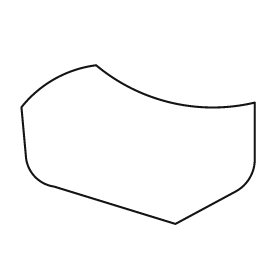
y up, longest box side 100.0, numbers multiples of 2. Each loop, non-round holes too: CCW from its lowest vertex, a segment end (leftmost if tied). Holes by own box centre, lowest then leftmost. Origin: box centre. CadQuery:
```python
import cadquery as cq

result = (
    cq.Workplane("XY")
    .moveTo(16.0, -34.0)
    .lineTo(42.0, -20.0)
    .threePointArc((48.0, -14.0), (50.0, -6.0))
    .lineTo(50.0, 18.0)
    .threePointArc((14.0, 18.0), (-18.0, 34.0))
    .threePointArc((-36.0, 28.0), (-50.0, 16.0))
    .lineTo(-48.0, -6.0)
    .threePointArc((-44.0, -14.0), (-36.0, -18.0))
    .close()
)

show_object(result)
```